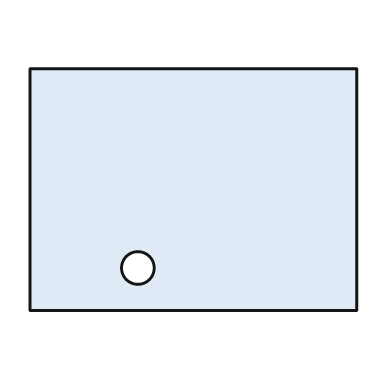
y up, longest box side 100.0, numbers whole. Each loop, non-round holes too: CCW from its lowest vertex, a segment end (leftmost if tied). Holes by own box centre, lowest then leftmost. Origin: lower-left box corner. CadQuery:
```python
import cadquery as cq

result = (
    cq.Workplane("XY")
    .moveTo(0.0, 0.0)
    .lineTo(100.0, 0.0)
    .lineTo(100.0, 74.0)
    .lineTo(0.0, 74.0)
    .close()
    .moveTo(33.0, 13.0)
    .circle(5.0)
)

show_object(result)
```